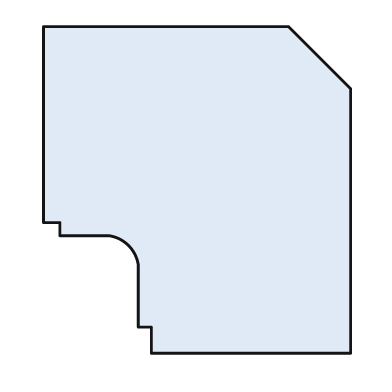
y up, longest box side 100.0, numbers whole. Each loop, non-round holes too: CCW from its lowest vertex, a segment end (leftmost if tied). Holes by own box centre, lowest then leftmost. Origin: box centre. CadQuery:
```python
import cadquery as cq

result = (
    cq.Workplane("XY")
    .moveTo(-14.0, -50.0)
    .lineTo(47.0, -50.0)
    .lineTo(47.0, 31.0)
    .lineTo(28.0, 50.0)
    .lineTo(-47.0, 50.0)
    .lineTo(-47.0, -10.0)
    .lineTo(-42.0, -10.0)
    .lineTo(-42.0, -14.0)
    .lineTo(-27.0, -14.0)
    .threePointArc((-21.0, -17.0), (-18.0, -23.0))
    .lineTo(-18.0, -42.0)
    .lineTo(-14.0, -42.0)
    .close()
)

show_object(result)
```